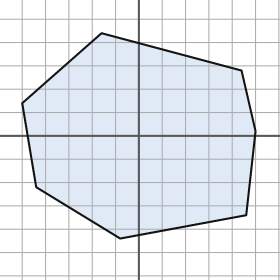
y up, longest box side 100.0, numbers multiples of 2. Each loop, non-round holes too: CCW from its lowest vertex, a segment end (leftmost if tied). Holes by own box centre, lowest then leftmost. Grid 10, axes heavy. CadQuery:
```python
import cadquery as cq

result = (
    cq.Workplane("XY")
    .moveTo(-8.0, -44.0)
    .lineTo(46.0, -34.0)
    .lineTo(50.0, 2.0)
    .lineTo(44.0, 28.0)
    .lineTo(-16.0, 44.0)
    .lineTo(-50.0, 14.0)
    .lineTo(-44.0, -22.0)
    .close()
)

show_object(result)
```